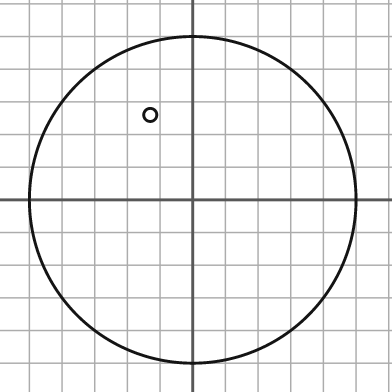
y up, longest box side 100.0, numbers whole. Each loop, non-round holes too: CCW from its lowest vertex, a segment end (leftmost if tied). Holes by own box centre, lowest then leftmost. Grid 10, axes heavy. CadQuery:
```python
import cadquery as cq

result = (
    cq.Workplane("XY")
    .moveTo(0.0, 0.0)
    .circle(50.0)
    .moveTo(-13.0, 26.0)
    .circle(2.0)
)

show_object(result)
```